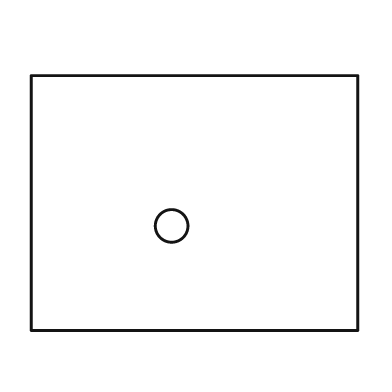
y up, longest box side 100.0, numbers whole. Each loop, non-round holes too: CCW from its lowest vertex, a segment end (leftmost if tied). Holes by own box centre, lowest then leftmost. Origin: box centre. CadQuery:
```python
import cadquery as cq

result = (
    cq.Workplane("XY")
    .moveTo(-50.0, -39.0)
    .lineTo(50.0, -39.0)
    .lineTo(50.0, 39.0)
    .lineTo(-50.0, 39.0)
    .close()
    .moveTo(-7.0, -7.0)
    .circle(5.0)
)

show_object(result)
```